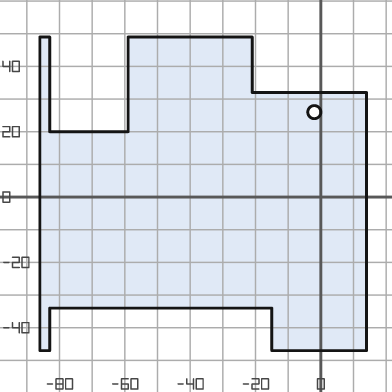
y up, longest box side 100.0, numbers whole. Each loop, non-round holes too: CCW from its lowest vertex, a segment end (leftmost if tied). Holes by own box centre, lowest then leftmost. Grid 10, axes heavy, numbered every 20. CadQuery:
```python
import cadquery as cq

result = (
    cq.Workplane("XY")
    .moveTo(-86.0, -47.0)
    .lineTo(-83.0, -47.0)
    .lineTo(-83.0, -34.0)
    .lineTo(-15.0, -34.0)
    .lineTo(-15.0, -47.0)
    .lineTo(14.0, -47.0)
    .lineTo(14.0, 32.0)
    .lineTo(-21.0, 32.0)
    .lineTo(-21.0, 49.0)
    .lineTo(-59.0, 49.0)
    .lineTo(-59.0, 20.0)
    .lineTo(-83.0, 20.0)
    .lineTo(-83.0, 49.0)
    .lineTo(-86.0, 49.0)
    .close()
    .moveTo(-2.0, 26.0)
    .circle(2.0)
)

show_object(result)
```